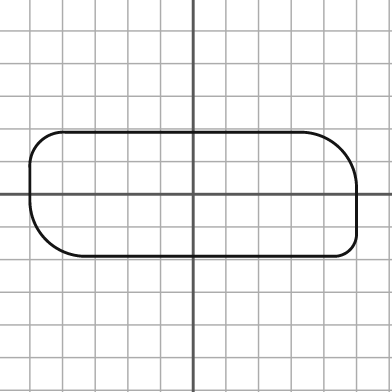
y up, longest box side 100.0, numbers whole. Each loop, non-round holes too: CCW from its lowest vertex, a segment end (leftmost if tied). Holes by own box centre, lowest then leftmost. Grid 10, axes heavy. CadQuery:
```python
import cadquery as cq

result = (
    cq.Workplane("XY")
    .moveTo(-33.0, -19.0)
    .lineTo(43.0, -19.0)
    .threePointArc((48.0, -17.0), (50.0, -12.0))
    .lineTo(50.0, 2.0)
    .threePointArc((45.0, 14.0), (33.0, 19.0))
    .lineTo(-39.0, 19.0)
    .threePointArc((-47.0, 16.0), (-50.0, 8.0))
    .lineTo(-50.0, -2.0)
    .threePointArc((-45.0, -14.0), (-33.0, -19.0))
    .close()
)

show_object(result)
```